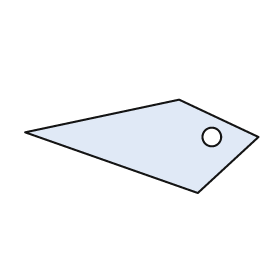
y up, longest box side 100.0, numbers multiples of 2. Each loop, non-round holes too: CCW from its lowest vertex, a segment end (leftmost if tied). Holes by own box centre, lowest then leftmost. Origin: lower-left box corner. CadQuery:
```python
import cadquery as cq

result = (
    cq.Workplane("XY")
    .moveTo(74.0, 0.0)
    .lineTo(100.0, 24.0)
    .lineTo(66.0, 40.0)
    .lineTo(0.0, 26.0)
    .close()
    .moveTo(80.0, 24.0)
    .circle(4.0)
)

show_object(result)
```